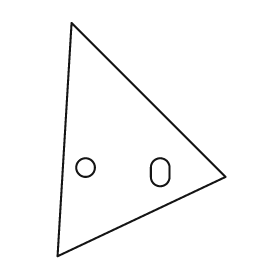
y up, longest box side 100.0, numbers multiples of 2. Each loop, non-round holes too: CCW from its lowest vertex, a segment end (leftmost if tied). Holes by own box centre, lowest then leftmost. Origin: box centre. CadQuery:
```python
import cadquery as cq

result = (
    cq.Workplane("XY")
    .moveTo(-36.0, -50.0)
    .lineTo(36.0, -16.0)
    .lineTo(-30.0, 50.0)
    .close()
    .moveTo(4.0, -16.0)
    .threePointArc((8.0, -20.0), (12.0, -16.0))
    .lineTo(12.0, -12.0)
    .threePointArc((8.0, -8.0), (4.0, -12.0))
    .close()
    .moveTo(-24.0, -12.0)
    .circle(4.0)
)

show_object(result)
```